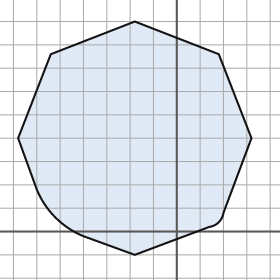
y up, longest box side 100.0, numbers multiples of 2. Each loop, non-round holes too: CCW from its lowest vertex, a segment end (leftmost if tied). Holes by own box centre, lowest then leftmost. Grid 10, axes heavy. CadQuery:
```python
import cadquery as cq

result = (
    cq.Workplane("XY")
    .moveTo(-18.0, -10.0)
    .lineTo(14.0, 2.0)
    .threePointArc((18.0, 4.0), (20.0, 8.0))
    .lineTo(32.0, 40.0)
    .lineTo(18.0, 76.0)
    .lineTo(-18.0, 90.0)
    .lineTo(-54.0, 76.0)
    .lineTo(-68.0, 40.0)
    .lineTo(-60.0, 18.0)
    .threePointArc((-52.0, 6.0), (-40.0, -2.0))
    .close()
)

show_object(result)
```